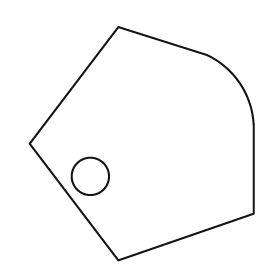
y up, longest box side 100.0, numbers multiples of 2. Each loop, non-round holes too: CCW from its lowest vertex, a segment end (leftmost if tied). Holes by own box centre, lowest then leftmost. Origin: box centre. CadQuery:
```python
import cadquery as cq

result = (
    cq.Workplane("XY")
    .moveTo(-10.0, -50.0)
    .lineTo(48.0, -30.0)
    .lineTo(48.0, 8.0)
    .threePointArc((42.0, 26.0), (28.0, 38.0))
    .lineTo(-10.0, 50.0)
    .lineTo(-48.0, 0.0)
    .close()
    .moveTo(-22.0, -14.0)
    .circle(8.0)
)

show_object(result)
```